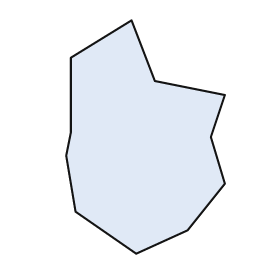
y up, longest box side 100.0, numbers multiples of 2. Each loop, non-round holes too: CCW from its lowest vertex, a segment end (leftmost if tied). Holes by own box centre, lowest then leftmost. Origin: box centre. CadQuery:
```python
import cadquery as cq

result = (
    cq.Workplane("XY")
    .moveTo(-4.0, -50.0)
    .lineTo(18.0, -40.0)
    .lineTo(34.0, -20.0)
    .lineTo(28.0, 0.0)
    .lineTo(34.0, 18.0)
    .lineTo(4.0, 24.0)
    .lineTo(-6.0, 50.0)
    .lineTo(-32.0, 34.0)
    .lineTo(-32.0, 2.0)
    .lineTo(-34.0, -8.0)
    .lineTo(-30.0, -32.0)
    .close()
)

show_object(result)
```